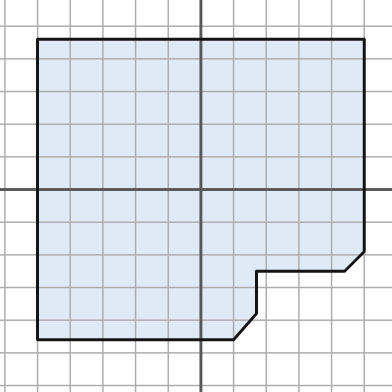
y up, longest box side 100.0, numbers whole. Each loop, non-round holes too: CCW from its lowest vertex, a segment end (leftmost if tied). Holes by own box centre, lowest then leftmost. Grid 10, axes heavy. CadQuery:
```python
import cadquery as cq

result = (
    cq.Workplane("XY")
    .moveTo(-50.0, -46.0)
    .lineTo(10.0, -46.0)
    .lineTo(17.0, -38.0)
    .lineTo(17.0, -25.0)
    .lineTo(44.0, -25.0)
    .lineTo(50.0, -19.0)
    .lineTo(50.0, 46.0)
    .lineTo(-50.0, 46.0)
    .close()
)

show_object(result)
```